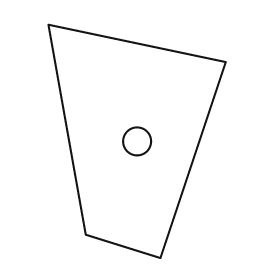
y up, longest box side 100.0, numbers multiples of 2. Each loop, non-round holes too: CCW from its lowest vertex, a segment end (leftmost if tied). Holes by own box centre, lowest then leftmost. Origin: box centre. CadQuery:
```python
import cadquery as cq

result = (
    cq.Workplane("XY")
    .moveTo(10.0, -50.0)
    .lineTo(38.0, 34.0)
    .lineTo(-38.0, 50.0)
    .lineTo(-22.0, -40.0)
    .close()
    .moveTo(0.0, 0.0)
    .circle(6.0)
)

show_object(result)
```